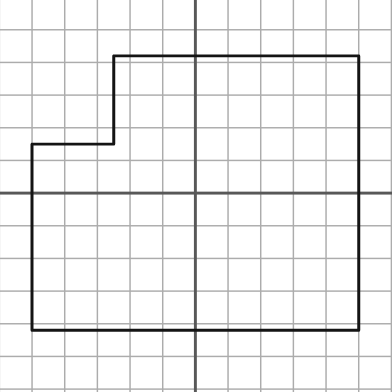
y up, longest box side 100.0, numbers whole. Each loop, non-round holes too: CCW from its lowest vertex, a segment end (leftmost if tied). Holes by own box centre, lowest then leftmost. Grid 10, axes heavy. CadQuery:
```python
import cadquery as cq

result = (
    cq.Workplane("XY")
    .moveTo(-50.0, -42.0)
    .lineTo(50.0, -42.0)
    .lineTo(50.0, 42.0)
    .lineTo(-25.0, 42.0)
    .lineTo(-25.0, 15.0)
    .lineTo(-50.0, 15.0)
    .close()
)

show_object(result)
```